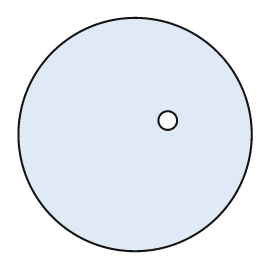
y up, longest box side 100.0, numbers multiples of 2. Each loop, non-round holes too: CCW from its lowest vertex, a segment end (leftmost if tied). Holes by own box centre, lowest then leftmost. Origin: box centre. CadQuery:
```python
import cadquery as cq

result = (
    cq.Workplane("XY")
    .moveTo(0.0, 0.0)
    .circle(50.0)
    .moveTo(14.0, 6.0)
    .circle(4.0)
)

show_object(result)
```